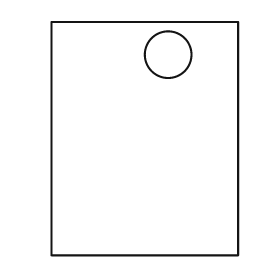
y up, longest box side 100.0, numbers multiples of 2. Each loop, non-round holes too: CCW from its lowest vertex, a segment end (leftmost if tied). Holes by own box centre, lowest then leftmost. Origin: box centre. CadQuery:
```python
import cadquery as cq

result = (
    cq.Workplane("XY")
    .moveTo(-40.0, -50.0)
    .lineTo(40.0, -50.0)
    .lineTo(40.0, 50.0)
    .lineTo(-40.0, 50.0)
    .close()
    .moveTo(10.0, 36.0)
    .circle(10.0)
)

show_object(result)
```